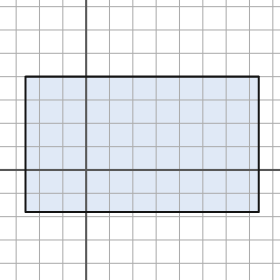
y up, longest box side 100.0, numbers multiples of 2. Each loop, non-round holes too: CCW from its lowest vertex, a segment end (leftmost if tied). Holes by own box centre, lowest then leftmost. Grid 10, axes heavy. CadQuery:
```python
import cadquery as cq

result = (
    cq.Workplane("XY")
    .moveTo(-26.0, -18.0)
    .lineTo(74.0, -18.0)
    .lineTo(74.0, 40.0)
    .lineTo(-26.0, 40.0)
    .close()
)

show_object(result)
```